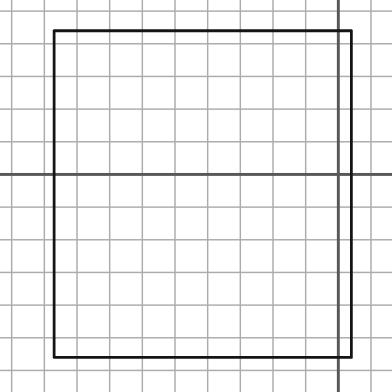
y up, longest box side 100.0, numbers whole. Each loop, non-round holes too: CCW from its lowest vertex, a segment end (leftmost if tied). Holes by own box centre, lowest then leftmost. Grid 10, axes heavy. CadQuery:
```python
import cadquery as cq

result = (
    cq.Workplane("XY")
    .moveTo(-87.0, -56.0)
    .lineTo(4.0, -56.0)
    .lineTo(4.0, 44.0)
    .lineTo(-87.0, 44.0)
    .close()
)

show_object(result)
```